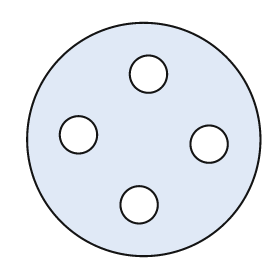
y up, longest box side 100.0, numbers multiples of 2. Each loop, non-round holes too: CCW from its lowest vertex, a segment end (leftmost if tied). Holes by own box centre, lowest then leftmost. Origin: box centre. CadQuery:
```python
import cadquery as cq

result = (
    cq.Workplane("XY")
    .moveTo(0.0, 0.0)
    .circle(50.0)
    .moveTo(-2.0, -28.0)
    .circle(8.0)
    .moveTo(28.0, -2.0)
    .circle(8.0)
    .moveTo(-28.0, 2.0)
    .circle(8.0)
    .moveTo(2.0, 28.0)
    .circle(8.0)
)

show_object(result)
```